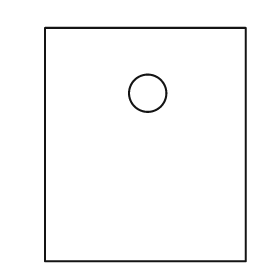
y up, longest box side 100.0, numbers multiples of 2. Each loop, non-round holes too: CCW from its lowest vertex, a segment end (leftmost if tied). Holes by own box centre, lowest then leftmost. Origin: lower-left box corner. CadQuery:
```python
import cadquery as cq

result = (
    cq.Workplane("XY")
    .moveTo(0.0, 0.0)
    .lineTo(86.0, 0.0)
    .lineTo(86.0, 100.0)
    .lineTo(0.0, 100.0)
    .close()
    .moveTo(44.0, 72.0)
    .circle(8.0)
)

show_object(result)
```